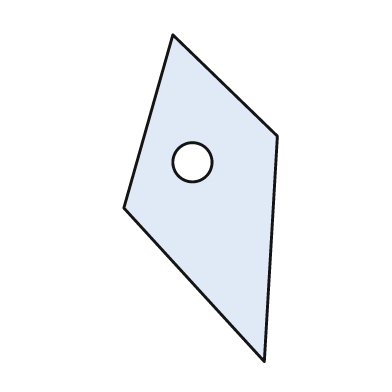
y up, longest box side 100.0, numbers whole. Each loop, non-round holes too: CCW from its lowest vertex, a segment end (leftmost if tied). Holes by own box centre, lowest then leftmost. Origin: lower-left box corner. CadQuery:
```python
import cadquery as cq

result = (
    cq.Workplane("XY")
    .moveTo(43.0, 0.0)
    .lineTo(47.0, 69.0)
    .lineTo(15.0, 100.0)
    .lineTo(0.0, 47.0)
    .close()
    .moveTo(21.0, 61.0)
    .circle(6.0)
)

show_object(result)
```